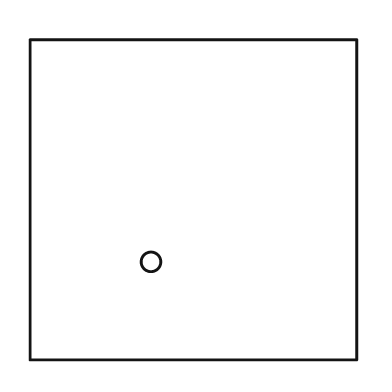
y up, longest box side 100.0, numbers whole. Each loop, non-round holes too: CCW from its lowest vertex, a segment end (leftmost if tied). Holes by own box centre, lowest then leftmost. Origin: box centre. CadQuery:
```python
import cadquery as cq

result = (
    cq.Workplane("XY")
    .moveTo(-50.0, -49.0)
    .lineTo(50.0, -49.0)
    .lineTo(50.0, 49.0)
    .lineTo(-50.0, 49.0)
    .close()
    .moveTo(-13.0, -19.0)
    .circle(3.0)
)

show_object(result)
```